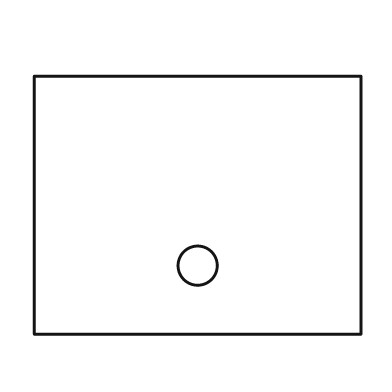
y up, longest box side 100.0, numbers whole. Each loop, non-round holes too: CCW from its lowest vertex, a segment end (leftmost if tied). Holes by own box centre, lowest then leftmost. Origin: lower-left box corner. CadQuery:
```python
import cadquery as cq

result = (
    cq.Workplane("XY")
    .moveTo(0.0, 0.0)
    .lineTo(100.0, 0.0)
    .lineTo(100.0, 79.0)
    .lineTo(0.0, 79.0)
    .close()
    .moveTo(50.0, 21.0)
    .circle(6.0)
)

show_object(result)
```